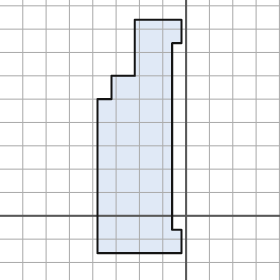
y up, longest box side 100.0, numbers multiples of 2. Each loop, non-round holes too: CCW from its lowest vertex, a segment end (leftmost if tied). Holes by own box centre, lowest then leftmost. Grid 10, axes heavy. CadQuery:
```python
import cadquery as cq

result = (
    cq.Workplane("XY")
    .moveTo(-38.0, -16.0)
    .lineTo(-2.0, -16.0)
    .lineTo(-2.0, -6.0)
    .lineTo(-6.0, -6.0)
    .lineTo(-6.0, 74.0)
    .lineTo(-2.0, 74.0)
    .lineTo(-2.0, 84.0)
    .lineTo(-22.0, 84.0)
    .lineTo(-22.0, 60.0)
    .lineTo(-32.0, 60.0)
    .lineTo(-32.0, 50.0)
    .lineTo(-38.0, 50.0)
    .close()
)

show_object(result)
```